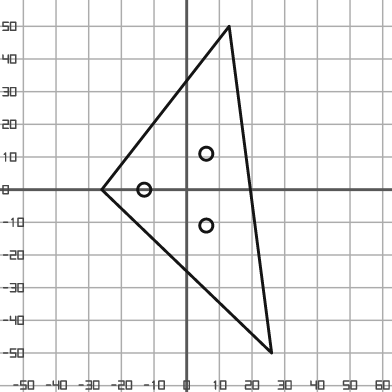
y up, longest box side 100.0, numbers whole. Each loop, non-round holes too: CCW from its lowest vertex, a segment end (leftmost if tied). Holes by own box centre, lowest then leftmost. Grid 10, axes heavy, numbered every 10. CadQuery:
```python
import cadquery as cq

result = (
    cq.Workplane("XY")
    .moveTo(26.0, -50.0)
    .lineTo(13.0, 50.0)
    .lineTo(-26.0, 0.0)
    .close()
    .moveTo(6.0, -11.0)
    .circle(2.0)
    .moveTo(-13.0, 0.0)
    .circle(2.0)
    .moveTo(6.0, 11.0)
    .circle(2.0)
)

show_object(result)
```